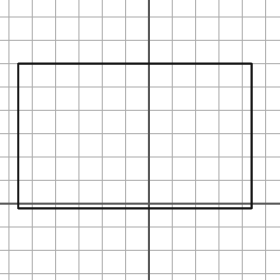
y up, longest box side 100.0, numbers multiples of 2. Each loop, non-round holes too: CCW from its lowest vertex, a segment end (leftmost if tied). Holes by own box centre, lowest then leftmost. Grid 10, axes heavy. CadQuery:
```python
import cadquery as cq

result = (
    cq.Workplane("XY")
    .moveTo(-56.0, -2.0)
    .lineTo(44.0, -2.0)
    .lineTo(44.0, 60.0)
    .lineTo(-56.0, 60.0)
    .close()
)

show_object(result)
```